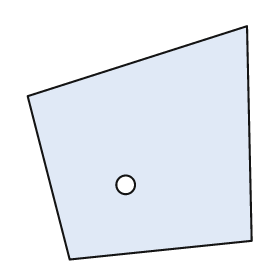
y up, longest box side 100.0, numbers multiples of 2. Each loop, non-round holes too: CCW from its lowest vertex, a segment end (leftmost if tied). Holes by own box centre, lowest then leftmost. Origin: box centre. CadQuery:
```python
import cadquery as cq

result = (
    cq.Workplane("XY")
    .moveTo(-30.0, -50.0)
    .lineTo(48.0, -42.0)
    .lineTo(46.0, 50.0)
    .lineTo(-48.0, 20.0)
    .close()
    .moveTo(-6.0, -18.0)
    .circle(4.0)
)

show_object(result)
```